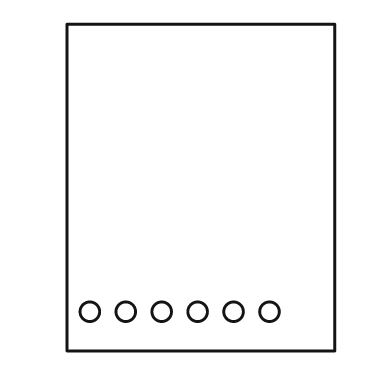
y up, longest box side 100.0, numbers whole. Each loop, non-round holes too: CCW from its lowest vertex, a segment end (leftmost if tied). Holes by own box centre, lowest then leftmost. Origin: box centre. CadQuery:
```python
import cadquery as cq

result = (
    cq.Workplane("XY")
    .moveTo(-41.0, -50.0)
    .lineTo(41.0, -50.0)
    .lineTo(41.0, 50.0)
    .lineTo(-41.0, 50.0)
    .close()
    .moveTo(-34.0, -38.0)
    .circle(3.0)
    .moveTo(-23.0, -38.0)
    .circle(3.0)
    .moveTo(-12.0, -38.0)
    .circle(3.0)
    .moveTo(-1.0, -38.0)
    .circle(3.0)
    .moveTo(10.0, -38.0)
    .circle(3.0)
    .moveTo(21.0, -38.0)
    .circle(3.0)
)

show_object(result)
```